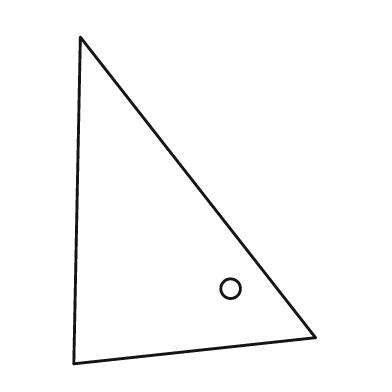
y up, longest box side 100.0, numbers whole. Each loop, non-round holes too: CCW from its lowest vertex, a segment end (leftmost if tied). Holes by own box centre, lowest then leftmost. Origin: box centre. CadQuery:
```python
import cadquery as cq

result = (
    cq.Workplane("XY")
    .moveTo(-37.0, -50.0)
    .lineTo(37.0, -42.0)
    .lineTo(-35.0, 50.0)
    .close()
    .moveTo(11.0, -27.0)
    .circle(3.0)
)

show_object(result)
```